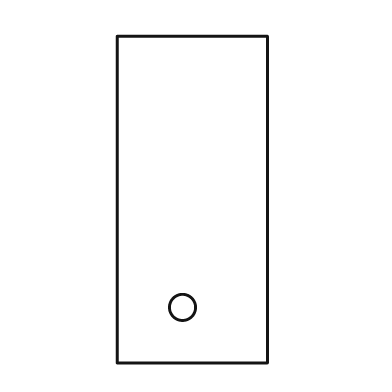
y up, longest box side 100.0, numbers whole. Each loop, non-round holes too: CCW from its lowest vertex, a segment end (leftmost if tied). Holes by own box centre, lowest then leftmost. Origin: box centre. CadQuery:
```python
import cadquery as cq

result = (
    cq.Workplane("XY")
    .moveTo(-23.0, -50.0)
    .lineTo(23.0, -50.0)
    .lineTo(23.0, 50.0)
    .lineTo(-23.0, 50.0)
    .close()
    .moveTo(-3.0, -33.0)
    .circle(4.0)
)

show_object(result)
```